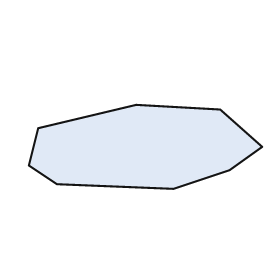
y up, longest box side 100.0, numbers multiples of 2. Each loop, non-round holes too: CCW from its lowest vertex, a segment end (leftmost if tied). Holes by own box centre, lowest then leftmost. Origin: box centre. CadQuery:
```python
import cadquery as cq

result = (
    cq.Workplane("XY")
    .moveTo(12.0, -18.0)
    .lineTo(36.0, -10.0)
    .lineTo(50.0, 0.0)
    .lineTo(32.0, 16.0)
    .lineTo(-4.0, 18.0)
    .lineTo(-46.0, 8.0)
    .lineTo(-50.0, -8.0)
    .lineTo(-38.0, -16.0)
    .close()
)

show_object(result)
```